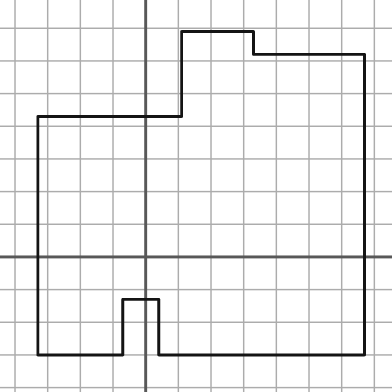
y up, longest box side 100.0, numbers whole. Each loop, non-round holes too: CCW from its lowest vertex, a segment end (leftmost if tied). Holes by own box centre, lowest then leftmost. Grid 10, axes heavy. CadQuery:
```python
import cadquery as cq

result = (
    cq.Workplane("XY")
    .moveTo(-33.0, -30.0)
    .lineTo(-7.0, -30.0)
    .lineTo(-7.0, -13.0)
    .lineTo(4.0, -13.0)
    .lineTo(4.0, -30.0)
    .lineTo(67.0, -30.0)
    .lineTo(67.0, 62.0)
    .lineTo(33.0, 62.0)
    .lineTo(33.0, 69.0)
    .lineTo(11.0, 69.0)
    .lineTo(11.0, 43.0)
    .lineTo(-33.0, 43.0)
    .close()
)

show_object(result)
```